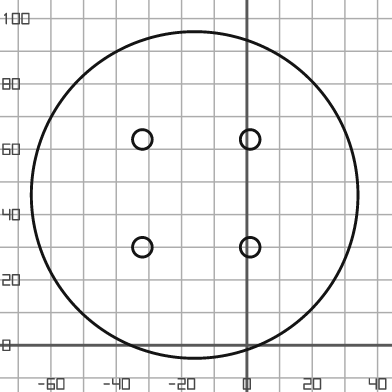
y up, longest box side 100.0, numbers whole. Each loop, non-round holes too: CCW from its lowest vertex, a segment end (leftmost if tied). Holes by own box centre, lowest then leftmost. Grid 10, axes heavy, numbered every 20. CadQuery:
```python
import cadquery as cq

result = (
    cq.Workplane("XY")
    .moveTo(-16.0, 46.0)
    .circle(50.0)
    .moveTo(-32.0, 30.0)
    .circle(3.0)
    .moveTo(1.0, 30.0)
    .circle(3.0)
    .moveTo(-32.0, 63.0)
    .circle(3.0)
    .moveTo(1.0, 63.0)
    .circle(3.0)
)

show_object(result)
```